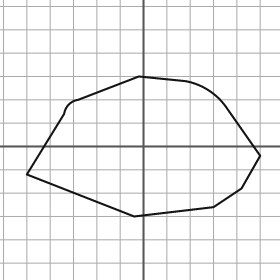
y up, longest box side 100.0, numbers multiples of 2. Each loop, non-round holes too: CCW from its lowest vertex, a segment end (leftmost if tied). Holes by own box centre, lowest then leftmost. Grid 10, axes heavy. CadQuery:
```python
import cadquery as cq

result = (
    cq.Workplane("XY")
    .moveTo(-4.0, -30.0)
    .lineTo(30.0, -26.0)
    .lineTo(42.0, -18.0)
    .lineTo(50.0, -4.0)
    .lineTo(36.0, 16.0)
    .threePointArc((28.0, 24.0), (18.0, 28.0))
    .lineTo(-2.0, 30.0)
    .lineTo(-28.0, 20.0)
    .threePointArc((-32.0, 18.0), (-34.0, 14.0))
    .lineTo(-50.0, -12.0)
    .close()
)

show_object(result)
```